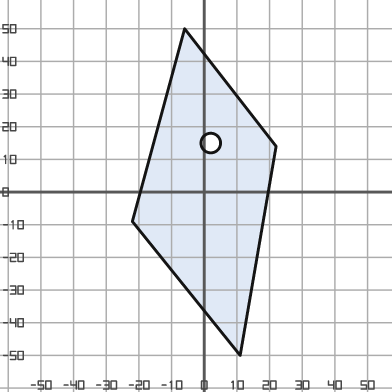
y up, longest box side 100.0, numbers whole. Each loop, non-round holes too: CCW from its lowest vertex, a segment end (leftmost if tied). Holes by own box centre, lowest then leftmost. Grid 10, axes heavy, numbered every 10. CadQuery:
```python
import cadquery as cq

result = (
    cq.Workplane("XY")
    .moveTo(11.0, -50.0)
    .lineTo(22.0, 14.0)
    .lineTo(-6.0, 50.0)
    .lineTo(-22.0, -9.0)
    .close()
    .moveTo(2.0, 15.0)
    .circle(3.0)
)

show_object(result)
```